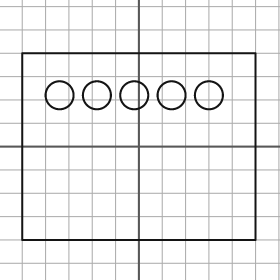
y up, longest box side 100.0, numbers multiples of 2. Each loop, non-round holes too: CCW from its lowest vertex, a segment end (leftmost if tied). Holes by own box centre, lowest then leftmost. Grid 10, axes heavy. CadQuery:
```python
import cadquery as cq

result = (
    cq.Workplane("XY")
    .moveTo(-50.0, -40.0)
    .lineTo(50.0, -40.0)
    .lineTo(50.0, 40.0)
    .lineTo(-50.0, 40.0)
    .close()
    .moveTo(-34.0, 22.0)
    .circle(6.0)
    .moveTo(-18.0, 22.0)
    .circle(6.0)
    .moveTo(-2.0, 22.0)
    .circle(6.0)
    .moveTo(14.0, 22.0)
    .circle(6.0)
    .moveTo(30.0, 22.0)
    .circle(6.0)
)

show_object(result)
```